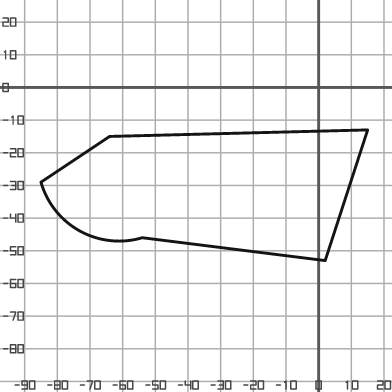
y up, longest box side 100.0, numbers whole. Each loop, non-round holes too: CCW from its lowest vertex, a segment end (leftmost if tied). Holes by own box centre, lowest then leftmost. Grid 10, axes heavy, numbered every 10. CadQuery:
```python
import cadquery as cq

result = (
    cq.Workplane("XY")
    .moveTo(2.0, -53.0)
    .lineTo(15.0, -13.0)
    .lineTo(-64.0, -15.0)
    .lineTo(-85.0, -29.0)
    .threePointArc((-73.0, -44.0), (-54.0, -46.0))
    .close()
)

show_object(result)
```